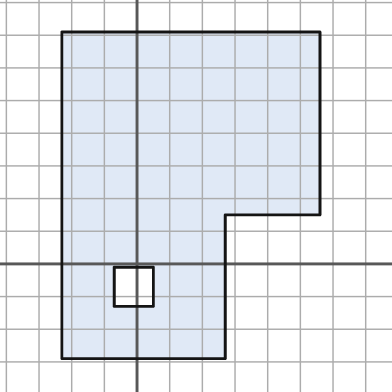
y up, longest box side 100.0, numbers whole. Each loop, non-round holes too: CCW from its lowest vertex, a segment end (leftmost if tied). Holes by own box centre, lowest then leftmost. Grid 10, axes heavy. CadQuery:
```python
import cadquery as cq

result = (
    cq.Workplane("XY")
    .moveTo(-23.0, -29.0)
    .lineTo(27.0, -29.0)
    .lineTo(27.0, 15.0)
    .lineTo(56.0, 15.0)
    .lineTo(56.0, 71.0)
    .lineTo(-23.0, 71.0)
    .close()
    .moveTo(-7.0, -13.0)
    .lineTo(5.0, -13.0)
    .lineTo(5.0, -1.0)
    .lineTo(-7.0, -1.0)
    .close()
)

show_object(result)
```